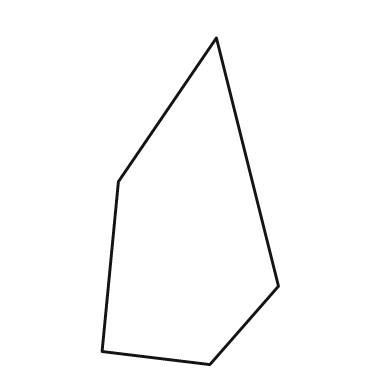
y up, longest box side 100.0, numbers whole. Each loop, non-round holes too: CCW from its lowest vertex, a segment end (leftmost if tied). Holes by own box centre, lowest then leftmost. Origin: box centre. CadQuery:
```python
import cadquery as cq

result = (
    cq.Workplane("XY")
    .moveTo(6.0, -50.0)
    .lineTo(27.0, -26.0)
    .lineTo(8.0, 50.0)
    .lineTo(-22.0, 6.0)
    .lineTo(-27.0, -46.0)
    .close()
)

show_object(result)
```